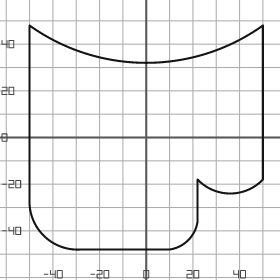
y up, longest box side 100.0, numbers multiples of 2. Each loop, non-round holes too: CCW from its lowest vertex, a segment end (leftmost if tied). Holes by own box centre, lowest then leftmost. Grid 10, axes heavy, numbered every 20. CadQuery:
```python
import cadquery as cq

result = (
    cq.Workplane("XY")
    .moveTo(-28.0, -48.0)
    .lineTo(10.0, -48.0)
    .threePointArc((18.0, -44.0), (22.0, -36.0))
    .lineTo(22.0, -18.0)
    .threePointArc((36.0, -24.0), (50.0, -18.0))
    .lineTo(50.0, 48.0)
    .threePointArc((0.0, 32.0), (-50.0, 48.0))
    .lineTo(-50.0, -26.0)
    .threePointArc((-44.0, -42.0), (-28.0, -48.0))
    .close()
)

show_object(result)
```